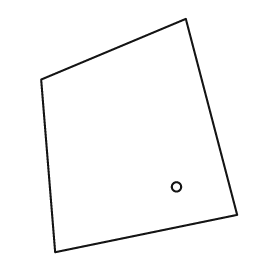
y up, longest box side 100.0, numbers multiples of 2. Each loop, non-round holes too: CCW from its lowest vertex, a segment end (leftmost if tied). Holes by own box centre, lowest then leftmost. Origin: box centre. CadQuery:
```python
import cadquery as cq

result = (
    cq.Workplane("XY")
    .moveTo(-36.0, -50.0)
    .lineTo(42.0, -34.0)
    .lineTo(20.0, 50.0)
    .lineTo(-42.0, 24.0)
    .close()
    .moveTo(16.0, -22.0)
    .circle(2.0)
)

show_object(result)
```